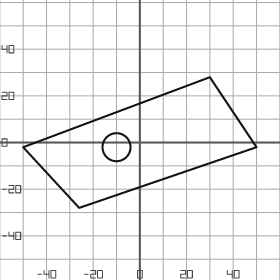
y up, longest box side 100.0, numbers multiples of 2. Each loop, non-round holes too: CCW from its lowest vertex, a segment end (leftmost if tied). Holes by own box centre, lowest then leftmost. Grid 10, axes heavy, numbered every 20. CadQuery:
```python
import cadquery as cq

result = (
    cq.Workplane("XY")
    .moveTo(-26.0, -28.0)
    .lineTo(50.0, -2.0)
    .lineTo(30.0, 28.0)
    .lineTo(-50.0, -2.0)
    .close()
    .moveTo(-10.0, -2.0)
    .circle(6.0)
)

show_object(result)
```